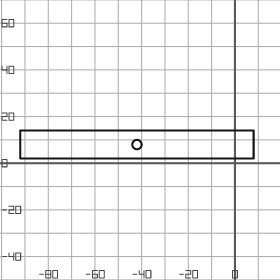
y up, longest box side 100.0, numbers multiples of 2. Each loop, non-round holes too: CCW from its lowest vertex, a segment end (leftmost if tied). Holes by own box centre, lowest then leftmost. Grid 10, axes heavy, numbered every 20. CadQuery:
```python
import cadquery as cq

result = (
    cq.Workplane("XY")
    .moveTo(-92.0, 2.0)
    .lineTo(8.0, 2.0)
    .lineTo(8.0, 14.0)
    .lineTo(-92.0, 14.0)
    .close()
    .moveTo(-42.0, 8.0)
    .circle(2.0)
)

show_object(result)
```